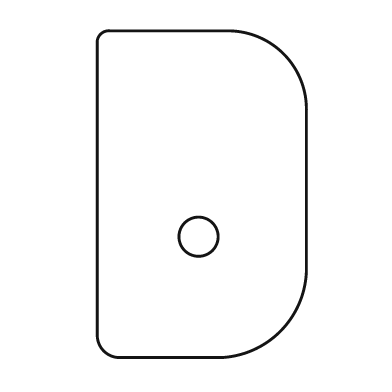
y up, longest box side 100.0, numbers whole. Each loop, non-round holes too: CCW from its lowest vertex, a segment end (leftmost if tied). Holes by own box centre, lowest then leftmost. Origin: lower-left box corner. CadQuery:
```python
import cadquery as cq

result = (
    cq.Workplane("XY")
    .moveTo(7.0, 0.0)
    .lineTo(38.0, 0.0)
    .threePointArc((56.0, 8.0), (64.0, 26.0))
    .lineTo(64.0, 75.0)
    .threePointArc((57.0, 93.0), (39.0, 100.0))
    .lineTo(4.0, 100.0)
    .threePointArc((1.0, 99.0), (0.0, 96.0))
    .lineTo(0.0, 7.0)
    .threePointArc((2.0, 2.0), (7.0, 0.0))
    .close()
    .moveTo(31.0, 37.0)
    .circle(6.0)
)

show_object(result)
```